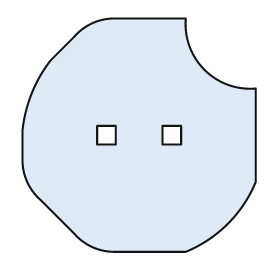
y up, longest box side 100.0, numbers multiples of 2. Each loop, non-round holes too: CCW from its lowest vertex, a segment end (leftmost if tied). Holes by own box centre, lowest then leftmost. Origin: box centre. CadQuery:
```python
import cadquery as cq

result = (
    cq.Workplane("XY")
    .moveTo(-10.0, -50.0)
    .lineTo(20.0, -50.0)
    .threePointArc((38.0, -38.0), (50.0, -20.0))
    .lineTo(50.0, 20.0)
    .threePointArc((28.0, 28.0), (20.0, 50.0))
    .lineTo(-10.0, 50.0)
    .threePointArc((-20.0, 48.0), (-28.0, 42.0))
    .lineTo(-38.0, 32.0)
    .threePointArc((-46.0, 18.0), (-50.0, 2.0))
    .lineTo(-50.0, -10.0)
    .threePointArc((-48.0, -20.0), (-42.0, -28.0))
    .lineTo(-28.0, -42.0)
    .threePointArc((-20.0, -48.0), (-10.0, -50.0))
    .close()
    .moveTo(-18.0, -4.0)
    .lineTo(-10.0, -4.0)
    .lineTo(-10.0, 4.0)
    .lineTo(-18.0, 4.0)
    .close()
    .moveTo(10.0, -4.0)
    .lineTo(18.0, -4.0)
    .lineTo(18.0, 4.0)
    .lineTo(10.0, 4.0)
    .close()
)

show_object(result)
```